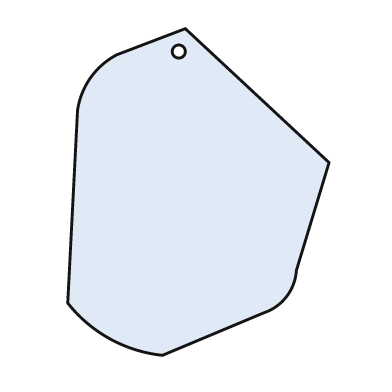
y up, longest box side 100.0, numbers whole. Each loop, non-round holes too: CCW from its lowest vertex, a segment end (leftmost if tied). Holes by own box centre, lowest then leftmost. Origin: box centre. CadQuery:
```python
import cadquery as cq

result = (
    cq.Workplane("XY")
    .moveTo(-11.0, -50.0)
    .lineTo(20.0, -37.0)
    .threePointArc((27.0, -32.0), (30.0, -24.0))
    .lineTo(40.0, 9.0)
    .lineTo(-4.0, 50.0)
    .lineTo(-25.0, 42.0)
    .threePointArc((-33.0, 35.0), (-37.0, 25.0))
    .lineTo(-40.0, -34.0)
    .threePointArc((-27.0, -45.0), (-11.0, -50.0))
    .close()
    .moveTo(-6.0, 43.0)
    .circle(2.0)
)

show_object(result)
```